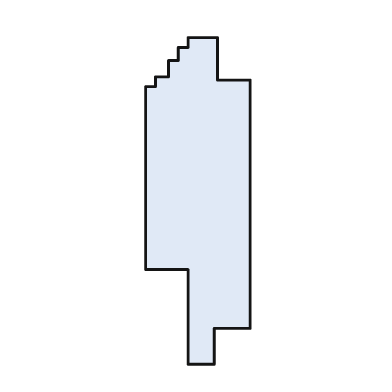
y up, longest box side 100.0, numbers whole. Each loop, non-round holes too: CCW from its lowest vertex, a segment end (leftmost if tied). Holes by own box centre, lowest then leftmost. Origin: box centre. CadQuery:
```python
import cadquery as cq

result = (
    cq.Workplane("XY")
    .moveTo(-3.0, -50.0)
    .lineTo(5.0, -50.0)
    .lineTo(5.0, -39.0)
    .lineTo(16.0, -39.0)
    .lineTo(16.0, 37.0)
    .lineTo(6.0, 37.0)
    .lineTo(6.0, 50.0)
    .lineTo(-3.0, 50.0)
    .lineTo(-3.0, 47.0)
    .lineTo(-6.0, 47.0)
    .lineTo(-6.0, 43.0)
    .lineTo(-9.0, 43.0)
    .lineTo(-9.0, 38.0)
    .lineTo(-13.0, 38.0)
    .lineTo(-13.0, 35.0)
    .lineTo(-16.0, 35.0)
    .lineTo(-16.0, -21.0)
    .lineTo(-3.0, -21.0)
    .close()
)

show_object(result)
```